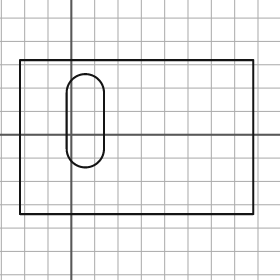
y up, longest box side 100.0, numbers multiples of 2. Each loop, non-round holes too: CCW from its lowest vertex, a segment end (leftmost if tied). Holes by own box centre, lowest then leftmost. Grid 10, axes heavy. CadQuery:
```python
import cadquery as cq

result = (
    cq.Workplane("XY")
    .moveTo(-22.0, -34.0)
    .lineTo(78.0, -34.0)
    .lineTo(78.0, 32.0)
    .lineTo(-22.0, 32.0)
    .close()
    .moveTo(-2.0, -6.0)
    .threePointArc((6.0, -14.0), (14.0, -6.0))
    .lineTo(14.0, 18.0)
    .threePointArc((6.0, 26.0), (-2.0, 18.0))
    .close()
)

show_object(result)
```